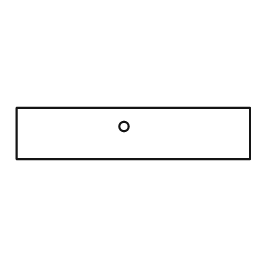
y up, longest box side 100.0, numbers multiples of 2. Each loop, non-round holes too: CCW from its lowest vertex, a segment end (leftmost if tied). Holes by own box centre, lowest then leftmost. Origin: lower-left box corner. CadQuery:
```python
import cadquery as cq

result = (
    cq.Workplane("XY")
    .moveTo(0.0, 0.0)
    .lineTo(100.0, 0.0)
    .lineTo(100.0, 22.0)
    .lineTo(0.0, 22.0)
    .close()
    .moveTo(46.0, 14.0)
    .circle(2.0)
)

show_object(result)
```